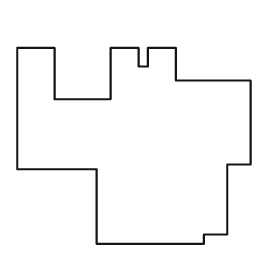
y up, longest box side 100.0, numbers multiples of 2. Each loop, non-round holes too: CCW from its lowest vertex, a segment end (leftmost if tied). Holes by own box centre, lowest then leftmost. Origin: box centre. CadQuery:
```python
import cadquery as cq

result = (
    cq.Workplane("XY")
    .moveTo(-16.0, -42.0)
    .lineTo(30.0, -42.0)
    .lineTo(30.0, -38.0)
    .lineTo(40.0, -38.0)
    .lineTo(40.0, -8.0)
    .lineTo(50.0, -8.0)
    .lineTo(50.0, 28.0)
    .lineTo(18.0, 28.0)
    .lineTo(18.0, 42.0)
    .lineTo(6.0, 42.0)
    .lineTo(6.0, 34.0)
    .lineTo(2.0, 34.0)
    .lineTo(2.0, 42.0)
    .lineTo(-10.0, 42.0)
    .lineTo(-10.0, 20.0)
    .lineTo(-34.0, 20.0)
    .lineTo(-34.0, 42.0)
    .lineTo(-50.0, 42.0)
    .lineTo(-50.0, -10.0)
    .lineTo(-16.0, -10.0)
    .close()
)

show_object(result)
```